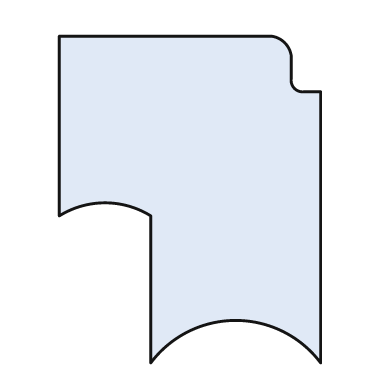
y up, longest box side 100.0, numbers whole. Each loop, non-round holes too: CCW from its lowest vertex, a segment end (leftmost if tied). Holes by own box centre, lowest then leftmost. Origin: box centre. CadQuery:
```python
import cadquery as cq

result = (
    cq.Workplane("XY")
    .moveTo(-12.0, -50.0)
    .threePointArc((14.0, -37.0), (40.0, -50.0))
    .lineTo(40.0, 33.0)
    .lineTo(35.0, 33.0)
    .threePointArc((32.0, 34.0), (31.0, 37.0))
    .lineTo(31.0, 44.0)
    .threePointArc((29.0, 48.0), (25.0, 50.0))
    .lineTo(-40.0, 50.0)
    .lineTo(-40.0, -5.0)
    .threePointArc((-26.0, -1.0), (-12.0, -5.0))
    .close()
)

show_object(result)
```